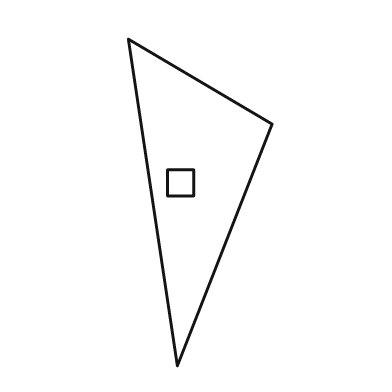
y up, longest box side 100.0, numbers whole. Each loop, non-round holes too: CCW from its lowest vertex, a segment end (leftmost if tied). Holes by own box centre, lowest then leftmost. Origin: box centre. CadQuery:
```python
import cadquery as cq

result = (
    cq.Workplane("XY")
    .moveTo(-7.0, -50.0)
    .lineTo(22.0, 24.0)
    .lineTo(-22.0, 50.0)
    .close()
    .moveTo(-10.0, 2.0)
    .lineTo(-2.0, 2.0)
    .lineTo(-2.0, 10.0)
    .lineTo(-10.0, 10.0)
    .close()
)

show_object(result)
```